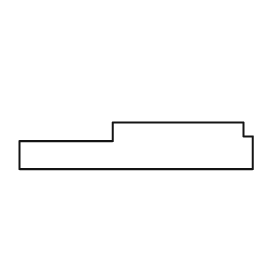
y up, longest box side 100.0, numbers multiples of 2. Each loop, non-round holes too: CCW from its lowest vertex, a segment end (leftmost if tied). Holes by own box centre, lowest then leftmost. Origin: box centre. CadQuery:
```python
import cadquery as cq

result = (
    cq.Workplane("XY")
    .moveTo(-50.0, -10.0)
    .lineTo(50.0, -10.0)
    .lineTo(50.0, 4.0)
    .lineTo(46.0, 4.0)
    .lineTo(46.0, 10.0)
    .lineTo(-10.0, 10.0)
    .lineTo(-10.0, 2.0)
    .lineTo(-50.0, 2.0)
    .close()
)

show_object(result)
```